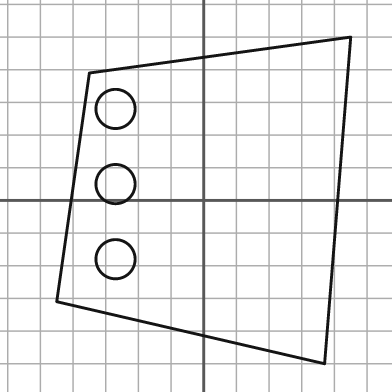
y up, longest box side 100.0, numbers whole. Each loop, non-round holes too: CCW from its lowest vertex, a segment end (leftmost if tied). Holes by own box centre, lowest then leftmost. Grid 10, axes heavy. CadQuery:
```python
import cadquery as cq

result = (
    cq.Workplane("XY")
    .moveTo(37.0, -50.0)
    .lineTo(45.0, 50.0)
    .lineTo(-35.0, 39.0)
    .lineTo(-45.0, -31.0)
    .close()
    .moveTo(-27.0, -18.0)
    .circle(6.0)
    .moveTo(-27.0, 5.0)
    .circle(6.0)
    .moveTo(-27.0, 28.0)
    .circle(6.0)
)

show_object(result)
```